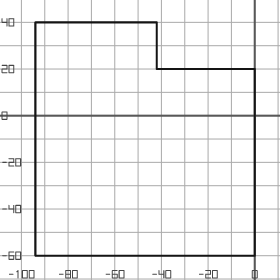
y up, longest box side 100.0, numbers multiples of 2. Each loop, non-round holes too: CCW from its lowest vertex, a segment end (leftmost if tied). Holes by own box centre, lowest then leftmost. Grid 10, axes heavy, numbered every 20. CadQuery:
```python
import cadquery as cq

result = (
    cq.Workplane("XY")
    .moveTo(-94.0, -60.0)
    .lineTo(0.0, -60.0)
    .lineTo(0.0, 20.0)
    .lineTo(-42.0, 20.0)
    .lineTo(-42.0, 40.0)
    .lineTo(-94.0, 40.0)
    .close()
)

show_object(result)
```